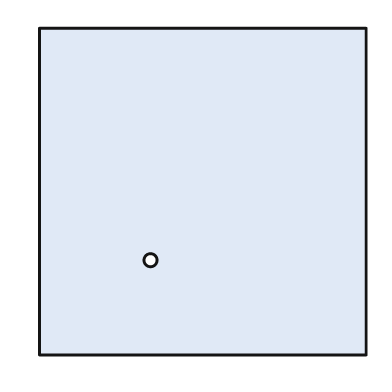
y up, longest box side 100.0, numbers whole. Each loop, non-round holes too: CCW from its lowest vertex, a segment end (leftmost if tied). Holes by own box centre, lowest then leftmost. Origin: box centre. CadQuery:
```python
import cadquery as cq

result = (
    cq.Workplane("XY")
    .moveTo(-50.0, -50.0)
    .lineTo(50.0, -50.0)
    .lineTo(50.0, 50.0)
    .lineTo(-50.0, 50.0)
    .close()
    .moveTo(-16.0, -21.0)
    .circle(2.0)
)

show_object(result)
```